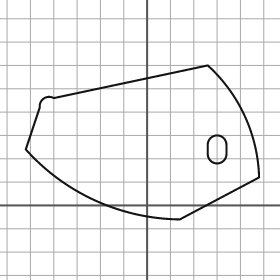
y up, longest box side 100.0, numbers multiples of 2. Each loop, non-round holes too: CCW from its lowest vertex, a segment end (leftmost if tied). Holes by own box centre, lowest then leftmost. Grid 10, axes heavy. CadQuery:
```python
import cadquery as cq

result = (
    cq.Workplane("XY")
    .moveTo(14.0, -6.0)
    .lineTo(48.0, 12.0)
    .threePointArc((42.0, 38.0), (26.0, 60.0))
    .lineTo(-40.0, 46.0)
    .threePointArc((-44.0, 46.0), (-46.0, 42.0))
    .lineTo(-52.0, 24.0)
    .threePointArc((-22.0, 2.0), (14.0, -6.0))
    .close()
    .moveTo(26.0, 22.0)
    .threePointArc((30.0, 18.0), (34.0, 22.0))
    .lineTo(34.0, 26.0)
    .threePointArc((30.0, 30.0), (26.0, 26.0))
    .close()
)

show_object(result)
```